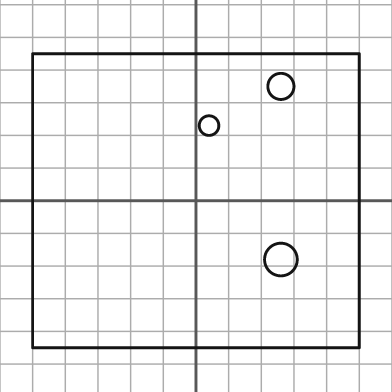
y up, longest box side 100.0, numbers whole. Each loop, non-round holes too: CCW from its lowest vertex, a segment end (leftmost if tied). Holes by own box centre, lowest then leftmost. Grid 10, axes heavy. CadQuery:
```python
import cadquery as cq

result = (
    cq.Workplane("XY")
    .moveTo(-50.0, -45.0)
    .lineTo(50.0, -45.0)
    .lineTo(50.0, 45.0)
    .lineTo(-50.0, 45.0)
    .close()
    .moveTo(26.0, -18.0)
    .circle(5.0)
    .moveTo(4.0, 23.0)
    .circle(3.0)
    .moveTo(26.0, 35.0)
    .circle(4.0)
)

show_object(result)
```